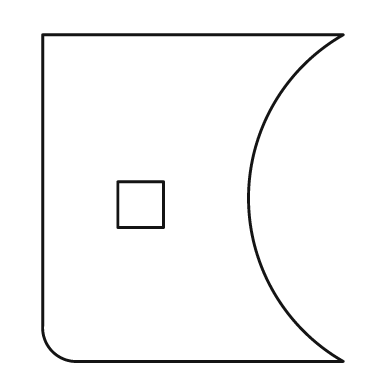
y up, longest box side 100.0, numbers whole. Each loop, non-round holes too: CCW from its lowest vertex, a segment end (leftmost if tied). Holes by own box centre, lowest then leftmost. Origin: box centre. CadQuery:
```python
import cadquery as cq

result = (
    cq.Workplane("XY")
    .moveTo(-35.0, -50.0)
    .lineTo(46.0, -50.0)
    .threePointArc((17.0, 0.0), (46.0, 50.0))
    .lineTo(-46.0, 50.0)
    .lineTo(-46.0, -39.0)
    .threePointArc((-43.0, -47.0), (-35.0, -50.0))
    .close()
    .moveTo(-23.0, -9.0)
    .lineTo(-9.0, -9.0)
    .lineTo(-9.0, 5.0)
    .lineTo(-23.0, 5.0)
    .close()
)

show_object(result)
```